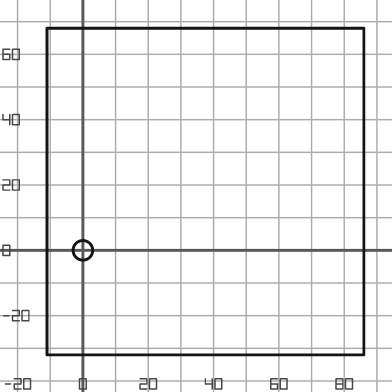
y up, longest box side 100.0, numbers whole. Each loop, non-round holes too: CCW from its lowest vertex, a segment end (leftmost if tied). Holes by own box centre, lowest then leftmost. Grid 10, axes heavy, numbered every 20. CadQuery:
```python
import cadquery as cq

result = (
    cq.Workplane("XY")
    .moveTo(-11.0, -32.0)
    .lineTo(86.0, -32.0)
    .lineTo(86.0, 68.0)
    .lineTo(-11.0, 68.0)
    .close()
    .moveTo(0.0, 0.0)
    .circle(3.0)
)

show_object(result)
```